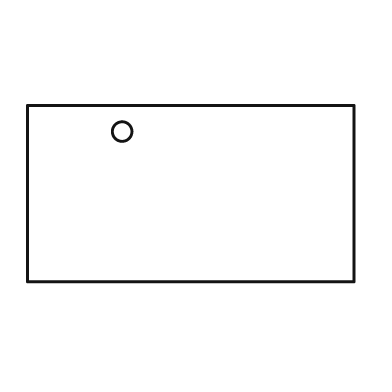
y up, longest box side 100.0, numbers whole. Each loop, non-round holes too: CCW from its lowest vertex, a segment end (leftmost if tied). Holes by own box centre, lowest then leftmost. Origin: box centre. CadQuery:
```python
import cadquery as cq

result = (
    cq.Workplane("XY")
    .moveTo(-50.0, -27.0)
    .lineTo(50.0, -27.0)
    .lineTo(50.0, 27.0)
    .lineTo(-50.0, 27.0)
    .close()
    .moveTo(-21.0, 19.0)
    .circle(3.0)
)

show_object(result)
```